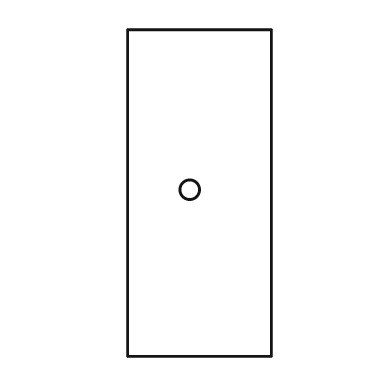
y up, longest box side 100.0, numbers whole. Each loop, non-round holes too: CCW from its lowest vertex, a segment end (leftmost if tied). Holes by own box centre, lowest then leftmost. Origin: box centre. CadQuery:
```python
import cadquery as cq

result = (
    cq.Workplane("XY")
    .moveTo(-22.0, -50.0)
    .lineTo(22.0, -50.0)
    .lineTo(22.0, 50.0)
    .lineTo(-22.0, 50.0)
    .close()
    .moveTo(-3.0, 1.0)
    .circle(3.0)
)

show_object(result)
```